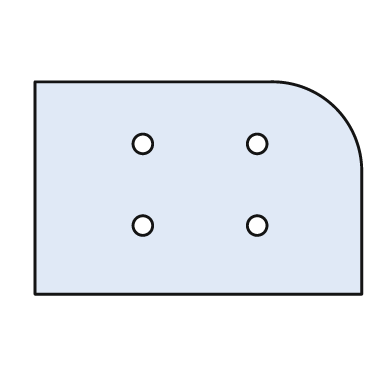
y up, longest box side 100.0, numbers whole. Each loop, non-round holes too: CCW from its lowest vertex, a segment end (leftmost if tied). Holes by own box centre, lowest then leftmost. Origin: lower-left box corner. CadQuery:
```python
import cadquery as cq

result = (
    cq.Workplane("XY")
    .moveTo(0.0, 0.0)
    .lineTo(100.0, 0.0)
    .lineTo(100.0, 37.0)
    .threePointArc((92.0, 57.0), (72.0, 65.0))
    .lineTo(0.0, 65.0)
    .close()
    .moveTo(33.0, 21.0)
    .circle(3.0)
    .moveTo(68.0, 21.0)
    .circle(3.0)
    .moveTo(33.0, 46.0)
    .circle(3.0)
    .moveTo(68.0, 46.0)
    .circle(3.0)
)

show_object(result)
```